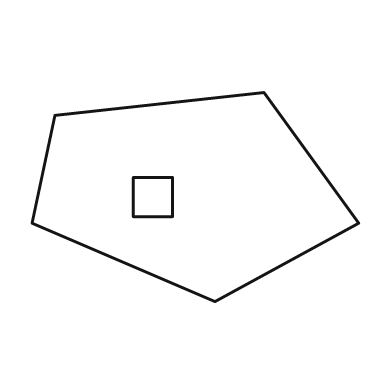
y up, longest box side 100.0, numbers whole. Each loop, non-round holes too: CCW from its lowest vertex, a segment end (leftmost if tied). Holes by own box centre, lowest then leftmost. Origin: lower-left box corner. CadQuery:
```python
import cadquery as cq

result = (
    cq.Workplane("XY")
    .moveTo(56.0, 0.0)
    .lineTo(100.0, 24.0)
    .lineTo(71.0, 64.0)
    .lineTo(7.0, 57.0)
    .lineTo(0.0, 24.0)
    .close()
    .moveTo(31.0, 26.0)
    .lineTo(43.0, 26.0)
    .lineTo(43.0, 38.0)
    .lineTo(31.0, 38.0)
    .close()
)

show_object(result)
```